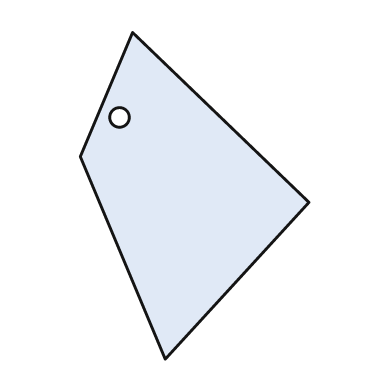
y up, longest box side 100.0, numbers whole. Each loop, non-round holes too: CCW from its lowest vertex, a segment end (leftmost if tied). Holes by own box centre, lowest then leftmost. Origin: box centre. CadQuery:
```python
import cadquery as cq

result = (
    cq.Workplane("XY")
    .moveTo(-9.0, -50.0)
    .lineTo(35.0, -2.0)
    .lineTo(-19.0, 50.0)
    .lineTo(-35.0, 12.0)
    .close()
    .moveTo(-23.0, 24.0)
    .circle(3.0)
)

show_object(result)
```